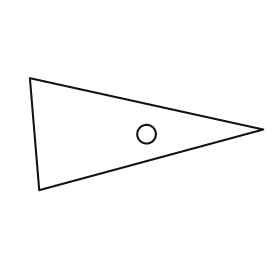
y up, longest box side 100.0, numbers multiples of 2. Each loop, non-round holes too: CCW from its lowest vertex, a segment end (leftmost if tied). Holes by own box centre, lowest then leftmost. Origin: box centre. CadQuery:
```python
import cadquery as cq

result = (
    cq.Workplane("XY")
    .moveTo(-46.0, -24.0)
    .lineTo(50.0, 2.0)
    .lineTo(-50.0, 24.0)
    .close()
    .moveTo(0.0, 0.0)
    .circle(4.0)
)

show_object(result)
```